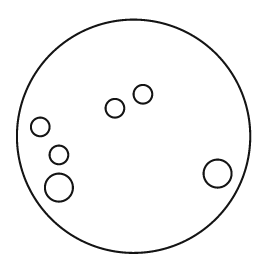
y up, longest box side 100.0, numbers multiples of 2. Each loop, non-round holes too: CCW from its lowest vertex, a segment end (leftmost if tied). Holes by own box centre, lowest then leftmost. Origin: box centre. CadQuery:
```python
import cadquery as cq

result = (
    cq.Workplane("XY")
    .moveTo(0.0, 0.0)
    .circle(50.0)
    .moveTo(-32.0, -22.0)
    .circle(6.0)
    .moveTo(36.0, -16.0)
    .circle(6.0)
    .moveTo(-32.0, -8.0)
    .circle(4.0)
    .moveTo(-40.0, 4.0)
    .circle(4.0)
    .moveTo(-8.0, 12.0)
    .circle(4.0)
    .moveTo(4.0, 18.0)
    .circle(4.0)
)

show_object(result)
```